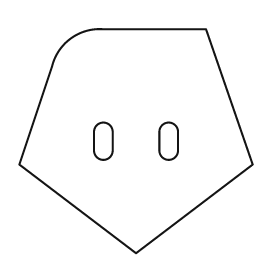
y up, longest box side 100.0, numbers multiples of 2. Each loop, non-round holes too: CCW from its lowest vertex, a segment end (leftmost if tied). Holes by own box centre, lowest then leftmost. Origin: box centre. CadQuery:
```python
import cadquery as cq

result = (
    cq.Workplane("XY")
    .moveTo(0.0, -48.0)
    .lineTo(50.0, -10.0)
    .lineTo(30.0, 48.0)
    .lineTo(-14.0, 48.0)
    .threePointArc((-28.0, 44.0), (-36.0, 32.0))
    .lineTo(-50.0, -10.0)
    .close()
    .moveTo(-18.0, -4.0)
    .threePointArc((-14.0, -8.0), (-10.0, -4.0))
    .lineTo(-10.0, 4.0)
    .threePointArc((-14.0, 8.0), (-18.0, 4.0))
    .close()
    .moveTo(10.0, -4.0)
    .threePointArc((14.0, -8.0), (18.0, -4.0))
    .lineTo(18.0, 4.0)
    .threePointArc((14.0, 8.0), (10.0, 4.0))
    .close()
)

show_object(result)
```